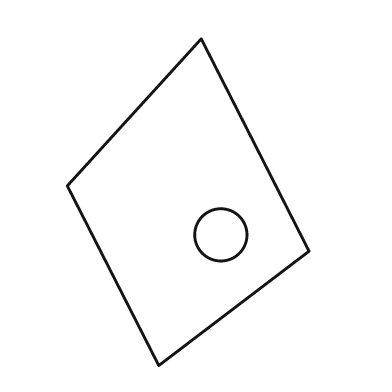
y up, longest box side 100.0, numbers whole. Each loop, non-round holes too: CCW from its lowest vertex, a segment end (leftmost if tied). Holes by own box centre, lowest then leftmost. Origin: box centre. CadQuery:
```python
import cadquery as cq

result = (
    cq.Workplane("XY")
    .moveTo(-9.0, -50.0)
    .lineTo(37.0, -15.0)
    .lineTo(4.0, 50.0)
    .lineTo(-37.0, 5.0)
    .close()
    .moveTo(10.0, -10.0)
    .circle(8.0)
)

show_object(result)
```